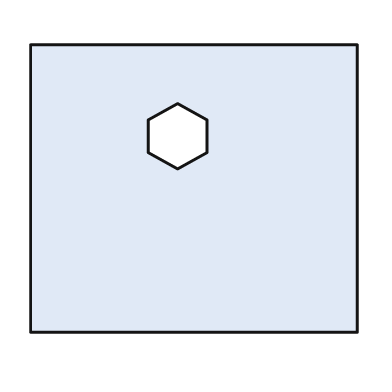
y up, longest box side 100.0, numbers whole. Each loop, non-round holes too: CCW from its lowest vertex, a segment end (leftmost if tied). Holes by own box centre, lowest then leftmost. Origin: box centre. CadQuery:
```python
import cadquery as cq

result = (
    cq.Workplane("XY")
    .moveTo(-50.0, -44.0)
    .lineTo(50.0, -44.0)
    .lineTo(50.0, 44.0)
    .lineTo(-50.0, 44.0)
    .close()
    .moveTo(-5.0, 6.0)
    .lineTo(4.0, 11.0)
    .lineTo(4.0, 21.0)
    .lineTo(-5.0, 26.0)
    .lineTo(-14.0, 21.0)
    .lineTo(-14.0, 11.0)
    .close()
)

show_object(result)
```